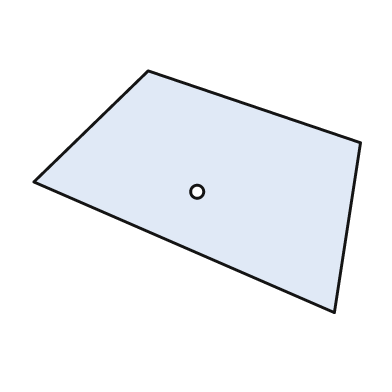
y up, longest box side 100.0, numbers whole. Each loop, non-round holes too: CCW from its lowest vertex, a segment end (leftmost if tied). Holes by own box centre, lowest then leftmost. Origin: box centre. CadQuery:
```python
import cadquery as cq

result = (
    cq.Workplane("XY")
    .moveTo(42.0, -37.0)
    .lineTo(50.0, 15.0)
    .lineTo(-15.0, 37.0)
    .lineTo(-50.0, 3.0)
    .close()
    .moveTo(0.0, 0.0)
    .circle(2.0)
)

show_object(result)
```